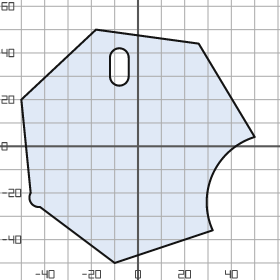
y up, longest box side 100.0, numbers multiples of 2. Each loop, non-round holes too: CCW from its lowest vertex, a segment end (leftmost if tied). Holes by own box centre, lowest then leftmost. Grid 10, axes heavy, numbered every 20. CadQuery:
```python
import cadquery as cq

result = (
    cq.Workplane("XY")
    .moveTo(-10.0, -50.0)
    .lineTo(32.0, -36.0)
    .threePointArc((32.0, -12.0), (50.0, 4.0))
    .lineTo(26.0, 44.0)
    .lineTo(-18.0, 50.0)
    .lineTo(-50.0, 20.0)
    .lineTo(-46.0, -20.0)
    .threePointArc((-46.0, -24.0), (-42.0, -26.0))
    .close()
    .moveTo(-12.0, 30.0)
    .threePointArc((-8.0, 26.0), (-4.0, 30.0))
    .lineTo(-4.0, 38.0)
    .threePointArc((-8.0, 42.0), (-12.0, 38.0))
    .close()
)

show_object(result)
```